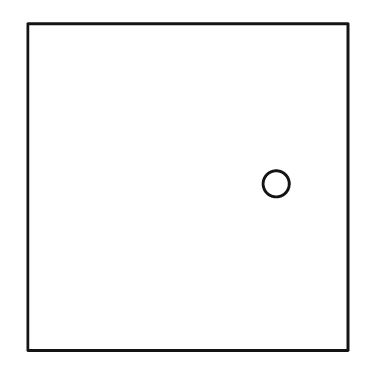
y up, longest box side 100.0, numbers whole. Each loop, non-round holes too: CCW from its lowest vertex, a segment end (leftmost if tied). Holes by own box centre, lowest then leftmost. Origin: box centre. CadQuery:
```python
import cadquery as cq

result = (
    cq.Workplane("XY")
    .moveTo(-49.0, -50.0)
    .lineTo(49.0, -50.0)
    .lineTo(49.0, 50.0)
    .lineTo(-49.0, 50.0)
    .close()
    .moveTo(27.0, 1.0)
    .circle(4.0)
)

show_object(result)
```